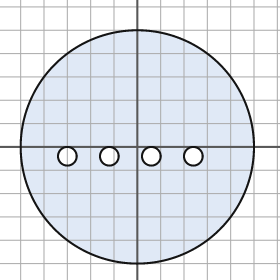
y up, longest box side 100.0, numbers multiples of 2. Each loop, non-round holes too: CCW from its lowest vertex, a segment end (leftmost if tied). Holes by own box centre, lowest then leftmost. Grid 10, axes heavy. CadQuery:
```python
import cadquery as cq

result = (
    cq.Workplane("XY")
    .moveTo(0.0, 0.0)
    .circle(50.0)
    .moveTo(-30.0, -4.0)
    .circle(4.0)
    .moveTo(-12.0, -4.0)
    .circle(4.0)
    .moveTo(6.0, -4.0)
    .circle(4.0)
    .moveTo(24.0, -4.0)
    .circle(4.0)
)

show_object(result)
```